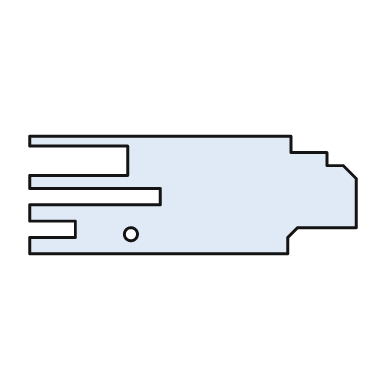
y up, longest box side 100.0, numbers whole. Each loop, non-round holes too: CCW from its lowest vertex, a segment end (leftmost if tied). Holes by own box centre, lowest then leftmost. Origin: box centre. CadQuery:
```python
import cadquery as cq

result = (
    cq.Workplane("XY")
    .moveTo(-50.0, -18.0)
    .lineTo(29.0, -18.0)
    .lineTo(29.0, -13.0)
    .lineTo(32.0, -10.0)
    .lineTo(50.0, -10.0)
    .lineTo(50.0, 5.0)
    .lineTo(46.0, 9.0)
    .lineTo(41.0, 9.0)
    .lineTo(41.0, 13.0)
    .lineTo(30.0, 13.0)
    .lineTo(30.0, 18.0)
    .lineTo(-50.0, 18.0)
    .lineTo(-50.0, 15.0)
    .lineTo(-20.0, 15.0)
    .lineTo(-20.0, 6.0)
    .lineTo(-50.0, 6.0)
    .lineTo(-50.0, 2.0)
    .lineTo(-10.0, 2.0)
    .lineTo(-10.0, -3.0)
    .lineTo(-50.0, -3.0)
    .lineTo(-50.0, -8.0)
    .lineTo(-36.0, -8.0)
    .lineTo(-36.0, -13.0)
    .lineTo(-50.0, -13.0)
    .close()
    .moveTo(-19.0, -12.0)
    .circle(2.0)
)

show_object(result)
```